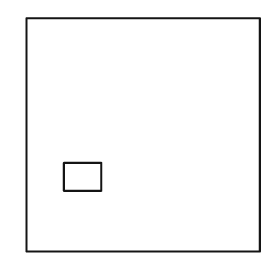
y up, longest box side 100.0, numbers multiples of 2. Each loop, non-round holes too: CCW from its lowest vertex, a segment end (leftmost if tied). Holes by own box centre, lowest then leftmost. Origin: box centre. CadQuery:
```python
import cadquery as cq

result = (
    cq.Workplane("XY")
    .moveTo(-50.0, -50.0)
    .lineTo(50.0, -50.0)
    .lineTo(50.0, 50.0)
    .lineTo(-50.0, 50.0)
    .close()
    .moveTo(-34.0, -24.0)
    .lineTo(-18.0, -24.0)
    .lineTo(-18.0, -12.0)
    .lineTo(-34.0, -12.0)
    .close()
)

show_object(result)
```